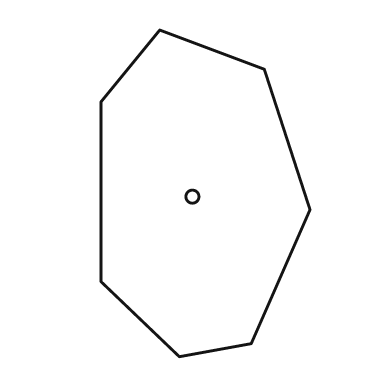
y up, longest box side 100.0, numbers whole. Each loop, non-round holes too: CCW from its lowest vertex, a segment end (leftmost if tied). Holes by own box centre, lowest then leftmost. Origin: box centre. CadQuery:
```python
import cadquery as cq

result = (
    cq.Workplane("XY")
    .moveTo(-8.0, -50.0)
    .lineTo(14.0, -46.0)
    .lineTo(32.0, -5.0)
    .lineTo(18.0, 38.0)
    .lineTo(-14.0, 50.0)
    .lineTo(-32.0, 28.0)
    .lineTo(-32.0, -27.0)
    .close()
    .moveTo(-4.0, -1.0)
    .circle(2.0)
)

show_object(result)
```